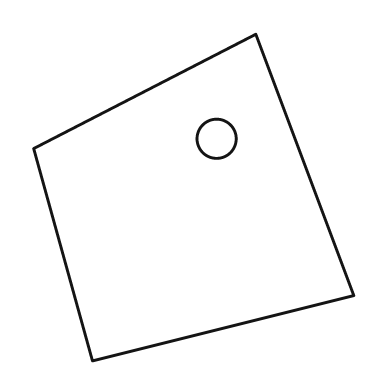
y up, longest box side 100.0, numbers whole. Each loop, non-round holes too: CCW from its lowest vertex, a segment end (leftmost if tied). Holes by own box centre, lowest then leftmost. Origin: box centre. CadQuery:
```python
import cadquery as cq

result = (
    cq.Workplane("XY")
    .moveTo(-31.0, -50.0)
    .lineTo(49.0, -30.0)
    .lineTo(19.0, 50.0)
    .lineTo(-49.0, 15.0)
    .close()
    .moveTo(7.0, 18.0)
    .circle(6.0)
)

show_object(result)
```